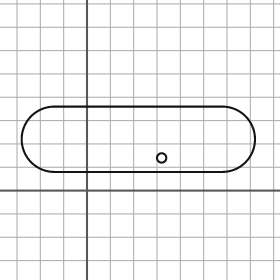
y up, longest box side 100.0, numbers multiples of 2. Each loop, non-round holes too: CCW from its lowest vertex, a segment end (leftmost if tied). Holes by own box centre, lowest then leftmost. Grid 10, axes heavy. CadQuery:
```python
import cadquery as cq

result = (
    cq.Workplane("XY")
    .moveTo(-14.0, 8.0)
    .lineTo(58.0, 8.0)
    .threePointArc((72.0, 22.0), (58.0, 36.0))
    .lineTo(-14.0, 36.0)
    .threePointArc((-28.0, 22.0), (-14.0, 8.0))
    .close()
    .moveTo(32.0, 14.0)
    .circle(2.0)
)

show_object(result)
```